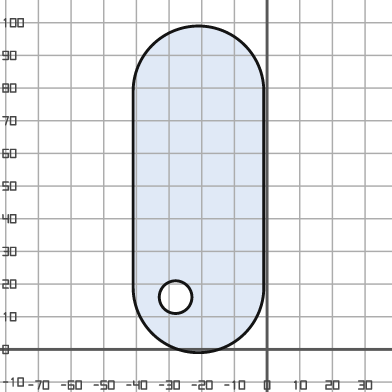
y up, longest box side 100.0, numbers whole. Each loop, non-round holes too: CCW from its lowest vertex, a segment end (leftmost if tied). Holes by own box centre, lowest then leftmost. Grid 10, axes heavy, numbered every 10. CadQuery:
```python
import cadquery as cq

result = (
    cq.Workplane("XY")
    .moveTo(-41.0, 19.0)
    .threePointArc((-21.0, -1.0), (-1.0, 19.0))
    .lineTo(-1.0, 79.0)
    .threePointArc((-21.0, 99.0), (-41.0, 79.0))
    .close()
    .moveTo(-28.0, 16.0)
    .circle(5.0)
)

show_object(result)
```